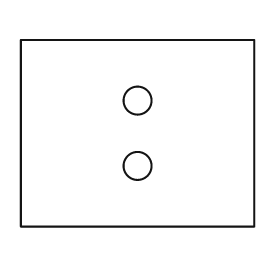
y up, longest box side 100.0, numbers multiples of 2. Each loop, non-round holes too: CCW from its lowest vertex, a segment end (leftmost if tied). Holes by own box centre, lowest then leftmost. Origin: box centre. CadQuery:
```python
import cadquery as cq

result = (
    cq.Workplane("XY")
    .moveTo(-50.0, -40.0)
    .lineTo(50.0, -40.0)
    .lineTo(50.0, 40.0)
    .lineTo(-50.0, 40.0)
    .close()
    .moveTo(0.0, -14.0)
    .circle(6.0)
    .moveTo(0.0, 14.0)
    .circle(6.0)
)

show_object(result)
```